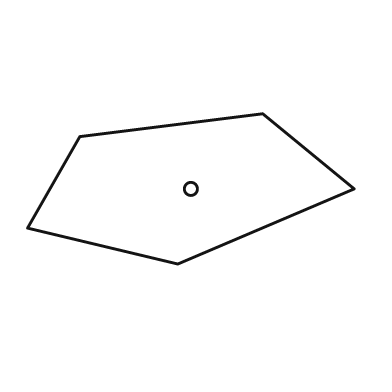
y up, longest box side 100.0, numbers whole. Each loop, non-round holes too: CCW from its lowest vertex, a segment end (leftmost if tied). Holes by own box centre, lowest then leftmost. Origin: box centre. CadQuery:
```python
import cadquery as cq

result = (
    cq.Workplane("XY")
    .moveTo(-4.0, -23.0)
    .lineTo(50.0, 0.0)
    .lineTo(22.0, 23.0)
    .lineTo(-34.0, 16.0)
    .lineTo(-50.0, -12.0)
    .close()
    .moveTo(0.0, 0.0)
    .circle(2.0)
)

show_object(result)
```